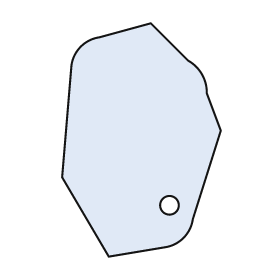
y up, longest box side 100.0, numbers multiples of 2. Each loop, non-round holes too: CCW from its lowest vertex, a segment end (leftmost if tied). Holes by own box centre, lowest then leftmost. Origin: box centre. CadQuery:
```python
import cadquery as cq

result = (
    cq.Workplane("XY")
    .moveTo(-14.0, -50.0)
    .lineTo(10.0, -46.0)
    .threePointArc((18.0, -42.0), (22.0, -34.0))
    .lineTo(34.0, 4.0)
    .lineTo(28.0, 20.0)
    .threePointArc((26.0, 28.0), (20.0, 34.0))
    .lineTo(4.0, 50.0)
    .lineTo(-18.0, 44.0)
    .threePointArc((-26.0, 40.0), (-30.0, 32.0))
    .lineTo(-34.0, -16.0)
    .close()
    .moveTo(12.0, -28.0)
    .circle(4.0)
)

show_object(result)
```